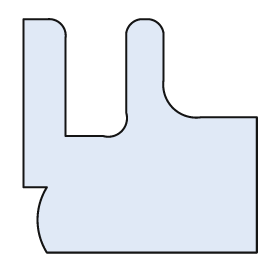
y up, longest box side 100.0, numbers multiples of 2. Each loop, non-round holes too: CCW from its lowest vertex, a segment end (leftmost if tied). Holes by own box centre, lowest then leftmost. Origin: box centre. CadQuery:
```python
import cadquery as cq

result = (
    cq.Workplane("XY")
    .moveTo(-40.0, -50.0)
    .lineTo(50.0, -50.0)
    .lineTo(50.0, 8.0)
    .lineTo(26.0, 8.0)
    .threePointArc((14.0, 12.0), (10.0, 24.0))
    .lineTo(10.0, 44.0)
    .threePointArc((8.0, 48.0), (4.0, 50.0))
    .lineTo(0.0, 50.0)
    .threePointArc((-4.0, 48.0), (-6.0, 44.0))
    .lineTo(-6.0, 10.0)
    .threePointArc((-8.0, 2.0), (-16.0, 0.0))
    .lineTo(-32.0, 0.0)
    .lineTo(-32.0, 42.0)
    .threePointArc((-34.0, 48.0), (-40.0, 50.0))
    .lineTo(-50.0, 50.0)
    .lineTo(-50.0, -22.0)
    .lineTo(-40.0, -22.0)
    .threePointArc((-44.0, -36.0), (-40.0, -50.0))
    .close()
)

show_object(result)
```